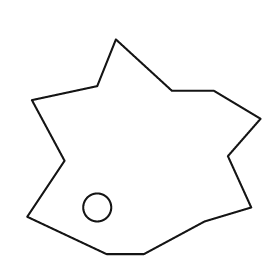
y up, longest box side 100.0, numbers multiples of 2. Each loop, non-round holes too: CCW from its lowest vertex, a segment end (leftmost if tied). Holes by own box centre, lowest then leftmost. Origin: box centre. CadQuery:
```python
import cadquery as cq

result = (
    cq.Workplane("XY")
    .moveTo(-16.0, -46.0)
    .lineTo(0.0, -46.0)
    .lineTo(26.0, -32.0)
    .lineTo(46.0, -26.0)
    .lineTo(36.0, -4.0)
    .lineTo(50.0, 12.0)
    .lineTo(30.0, 24.0)
    .lineTo(12.0, 24.0)
    .lineTo(-12.0, 46.0)
    .lineTo(-20.0, 26.0)
    .lineTo(-48.0, 20.0)
    .lineTo(-34.0, -6.0)
    .lineTo(-50.0, -30.0)
    .close()
    .moveTo(-20.0, -26.0)
    .circle(6.0)
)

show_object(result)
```